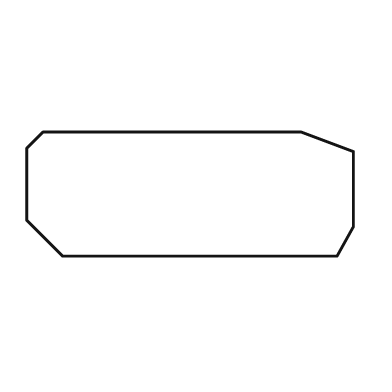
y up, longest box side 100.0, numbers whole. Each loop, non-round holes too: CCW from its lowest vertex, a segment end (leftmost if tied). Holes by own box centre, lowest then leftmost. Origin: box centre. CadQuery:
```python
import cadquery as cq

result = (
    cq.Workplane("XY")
    .moveTo(-39.0, -19.0)
    .lineTo(45.0, -19.0)
    .lineTo(50.0, -10.0)
    .lineTo(50.0, 13.0)
    .lineTo(34.0, 19.0)
    .lineTo(-45.0, 19.0)
    .lineTo(-50.0, 14.0)
    .lineTo(-50.0, -8.0)
    .close()
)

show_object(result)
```